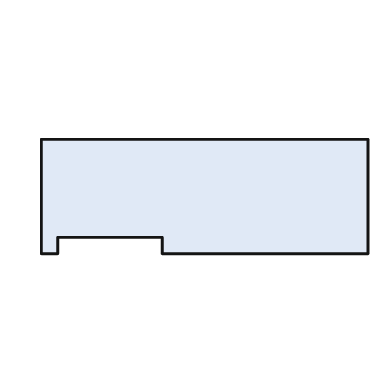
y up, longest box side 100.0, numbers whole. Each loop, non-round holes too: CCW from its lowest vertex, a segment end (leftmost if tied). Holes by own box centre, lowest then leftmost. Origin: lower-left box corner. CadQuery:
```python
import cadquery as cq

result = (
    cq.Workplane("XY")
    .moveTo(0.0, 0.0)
    .lineTo(5.0, 0.0)
    .lineTo(5.0, 5.0)
    .lineTo(37.0, 5.0)
    .lineTo(37.0, 0.0)
    .lineTo(100.0, 0.0)
    .lineTo(100.0, 35.0)
    .lineTo(0.0, 35.0)
    .close()
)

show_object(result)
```